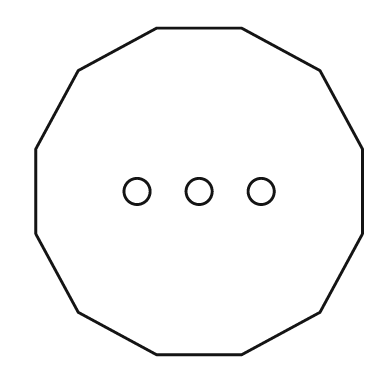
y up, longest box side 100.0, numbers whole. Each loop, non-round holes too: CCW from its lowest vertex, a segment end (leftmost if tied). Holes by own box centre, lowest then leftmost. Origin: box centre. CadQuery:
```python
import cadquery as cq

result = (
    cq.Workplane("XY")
    .moveTo(-13.0, -50.0)
    .lineTo(13.0, -50.0)
    .lineTo(37.0, -37.0)
    .lineTo(50.0, -13.0)
    .lineTo(50.0, 13.0)
    .lineTo(37.0, 37.0)
    .lineTo(13.0, 50.0)
    .lineTo(-13.0, 50.0)
    .lineTo(-37.0, 37.0)
    .lineTo(-50.0, 13.0)
    .lineTo(-50.0, -13.0)
    .lineTo(-37.0, -37.0)
    .close()
    .moveTo(-19.0, 0.0)
    .circle(4.0)
    .moveTo(0.0, 0.0)
    .circle(4.0)
    .moveTo(19.0, 0.0)
    .circle(4.0)
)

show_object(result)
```